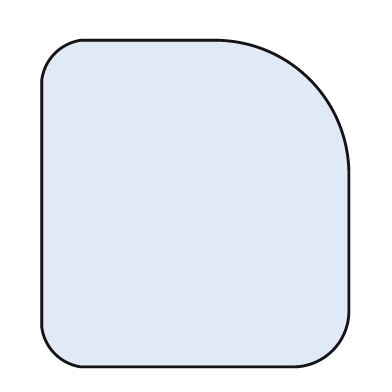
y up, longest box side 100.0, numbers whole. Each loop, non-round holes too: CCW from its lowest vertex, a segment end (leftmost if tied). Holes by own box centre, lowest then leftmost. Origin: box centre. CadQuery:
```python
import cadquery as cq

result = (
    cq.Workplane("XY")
    .moveTo(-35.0, -50.0)
    .lineTo(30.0, -50.0)
    .threePointArc((42.0, -45.0), (47.0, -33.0))
    .lineTo(47.0, 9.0)
    .threePointArc((35.0, 38.0), (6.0, 50.0))
    .lineTo(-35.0, 50.0)
    .threePointArc((-43.0, 46.0), (-47.0, 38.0))
    .lineTo(-47.0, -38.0)
    .threePointArc((-43.0, -46.0), (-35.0, -50.0))
    .close()
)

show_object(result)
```